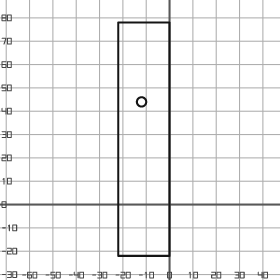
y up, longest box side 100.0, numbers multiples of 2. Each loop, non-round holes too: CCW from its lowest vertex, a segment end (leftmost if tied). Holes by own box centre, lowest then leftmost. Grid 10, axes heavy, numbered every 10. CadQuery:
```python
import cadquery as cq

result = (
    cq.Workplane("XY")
    .moveTo(-22.0, -22.0)
    .lineTo(0.0, -22.0)
    .lineTo(0.0, 78.0)
    .lineTo(-22.0, 78.0)
    .close()
    .moveTo(-12.0, 44.0)
    .circle(2.0)
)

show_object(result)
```